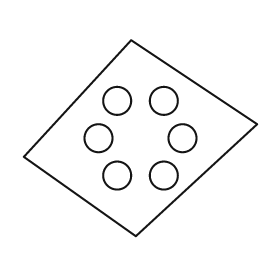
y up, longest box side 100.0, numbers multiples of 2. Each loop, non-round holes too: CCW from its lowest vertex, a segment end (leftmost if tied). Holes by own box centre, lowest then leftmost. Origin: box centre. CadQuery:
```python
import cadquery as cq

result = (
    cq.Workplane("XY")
    .moveTo(-2.0, -42.0)
    .lineTo(50.0, 6.0)
    .lineTo(-4.0, 42.0)
    .lineTo(-50.0, -8.0)
    .close()
    .moveTo(-10.0, -16.0)
    .circle(6.0)
    .moveTo(10.0, -16.0)
    .circle(6.0)
    .moveTo(-18.0, 0.0)
    .circle(6.0)
    .moveTo(18.0, 0.0)
    .circle(6.0)
    .moveTo(-10.0, 16.0)
    .circle(6.0)
    .moveTo(10.0, 16.0)
    .circle(6.0)
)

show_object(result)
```